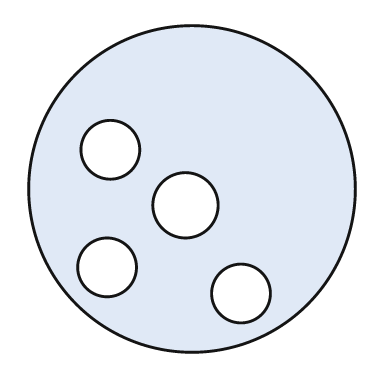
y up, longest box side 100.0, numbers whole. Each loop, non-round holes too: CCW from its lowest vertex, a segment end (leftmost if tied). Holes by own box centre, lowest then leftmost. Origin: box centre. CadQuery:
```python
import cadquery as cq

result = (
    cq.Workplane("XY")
    .moveTo(0.0, 0.0)
    .circle(50.0)
    .moveTo(15.0, -32.0)
    .circle(9.0)
    .moveTo(-26.0, -24.0)
    .circle(9.0)
    .moveTo(-2.0, -5.0)
    .circle(10.0)
    .moveTo(-25.0, 12.0)
    .circle(9.0)
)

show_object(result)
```